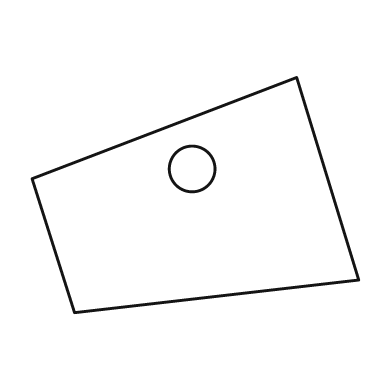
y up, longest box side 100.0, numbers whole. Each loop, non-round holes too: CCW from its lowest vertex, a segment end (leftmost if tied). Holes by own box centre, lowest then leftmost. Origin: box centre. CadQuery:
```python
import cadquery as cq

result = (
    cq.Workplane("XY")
    .moveTo(-37.0, -36.0)
    .lineTo(50.0, -26.0)
    .lineTo(31.0, 36.0)
    .lineTo(-50.0, 5.0)
    .close()
    .moveTo(-1.0, 8.0)
    .circle(7.0)
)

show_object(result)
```